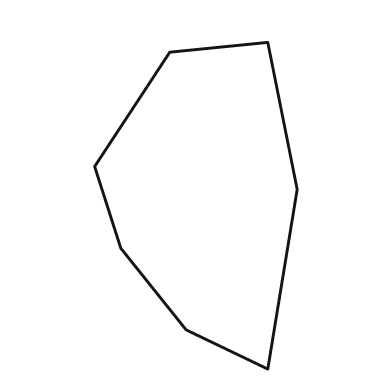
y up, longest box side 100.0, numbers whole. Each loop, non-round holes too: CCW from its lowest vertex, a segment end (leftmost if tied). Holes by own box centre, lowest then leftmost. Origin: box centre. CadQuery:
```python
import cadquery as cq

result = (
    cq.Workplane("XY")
    .moveTo(22.0, -50.0)
    .lineTo(31.0, 5.0)
    .lineTo(22.0, 50.0)
    .lineTo(-8.0, 47.0)
    .lineTo(-31.0, 12.0)
    .lineTo(-23.0, -13.0)
    .lineTo(-3.0, -38.0)
    .close()
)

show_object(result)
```